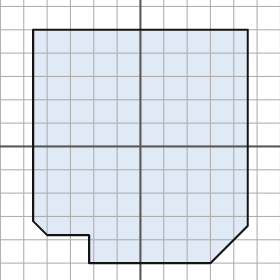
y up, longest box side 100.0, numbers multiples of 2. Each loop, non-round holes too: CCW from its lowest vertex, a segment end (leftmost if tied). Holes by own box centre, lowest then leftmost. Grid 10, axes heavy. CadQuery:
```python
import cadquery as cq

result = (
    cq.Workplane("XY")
    .moveTo(-22.0, -50.0)
    .lineTo(30.0, -50.0)
    .lineTo(46.0, -34.0)
    .lineTo(46.0, 50.0)
    .lineTo(-46.0, 50.0)
    .lineTo(-46.0, -32.0)
    .lineTo(-40.0, -38.0)
    .lineTo(-22.0, -38.0)
    .close()
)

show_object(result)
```